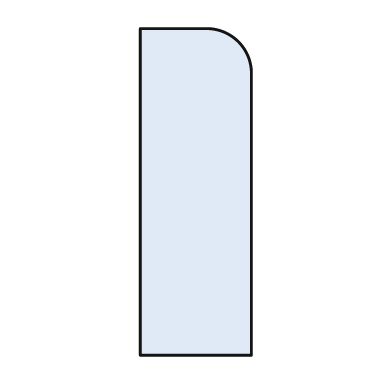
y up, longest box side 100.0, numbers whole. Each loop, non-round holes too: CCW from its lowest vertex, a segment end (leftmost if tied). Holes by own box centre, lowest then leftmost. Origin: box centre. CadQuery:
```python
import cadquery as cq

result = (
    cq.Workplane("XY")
    .moveTo(-17.0, -50.0)
    .lineTo(17.0, -50.0)
    .lineTo(17.0, 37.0)
    .threePointArc((13.0, 46.0), (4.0, 50.0))
    .lineTo(-17.0, 50.0)
    .close()
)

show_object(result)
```